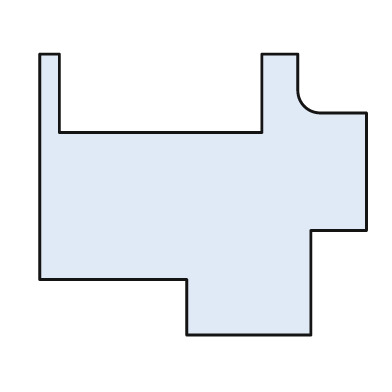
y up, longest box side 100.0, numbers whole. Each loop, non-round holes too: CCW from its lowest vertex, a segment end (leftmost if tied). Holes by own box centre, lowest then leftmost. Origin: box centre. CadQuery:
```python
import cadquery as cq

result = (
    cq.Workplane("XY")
    .moveTo(-5.0, -43.0)
    .lineTo(33.0, -43.0)
    .lineTo(33.0, -11.0)
    .lineTo(50.0, -11.0)
    .lineTo(50.0, 25.0)
    .lineTo(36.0, 25.0)
    .threePointArc((31.0, 27.0), (29.0, 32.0))
    .lineTo(29.0, 43.0)
    .lineTo(18.0, 43.0)
    .lineTo(18.0, 19.0)
    .lineTo(-44.0, 19.0)
    .lineTo(-44.0, 43.0)
    .lineTo(-50.0, 43.0)
    .lineTo(-50.0, -26.0)
    .lineTo(-5.0, -26.0)
    .close()
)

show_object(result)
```